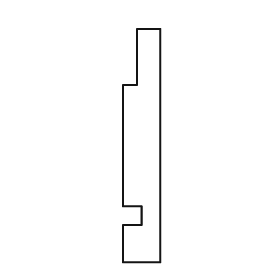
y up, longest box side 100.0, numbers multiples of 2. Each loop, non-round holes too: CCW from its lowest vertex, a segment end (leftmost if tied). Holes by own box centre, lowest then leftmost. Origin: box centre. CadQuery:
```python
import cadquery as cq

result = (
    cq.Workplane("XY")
    .moveTo(-8.0, -50.0)
    .lineTo(8.0, -50.0)
    .lineTo(8.0, 50.0)
    .lineTo(-2.0, 50.0)
    .lineTo(-2.0, 26.0)
    .lineTo(-8.0, 26.0)
    .lineTo(-8.0, -26.0)
    .lineTo(0.0, -26.0)
    .lineTo(0.0, -34.0)
    .lineTo(-8.0, -34.0)
    .close()
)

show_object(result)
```